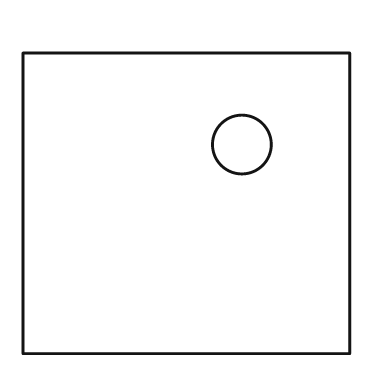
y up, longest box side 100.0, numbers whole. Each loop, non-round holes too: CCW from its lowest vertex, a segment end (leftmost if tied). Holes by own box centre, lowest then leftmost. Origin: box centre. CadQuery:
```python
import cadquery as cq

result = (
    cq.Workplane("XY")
    .moveTo(-50.0, -46.0)
    .lineTo(50.0, -46.0)
    .lineTo(50.0, 46.0)
    .lineTo(-50.0, 46.0)
    .close()
    .moveTo(17.0, 18.0)
    .circle(9.0)
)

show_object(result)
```